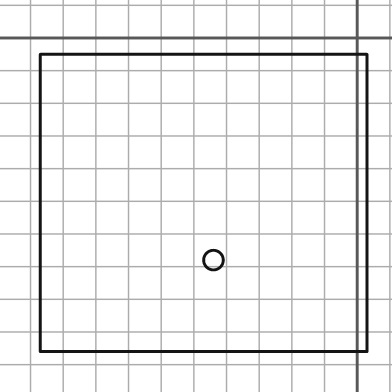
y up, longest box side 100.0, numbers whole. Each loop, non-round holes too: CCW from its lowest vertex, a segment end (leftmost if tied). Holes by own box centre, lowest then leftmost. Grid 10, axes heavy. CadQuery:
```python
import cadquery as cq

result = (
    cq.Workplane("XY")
    .moveTo(-97.0, -96.0)
    .lineTo(3.0, -96.0)
    .lineTo(3.0, -5.0)
    .lineTo(-97.0, -5.0)
    .close()
    .moveTo(-44.0, -68.0)
    .circle(3.0)
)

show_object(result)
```